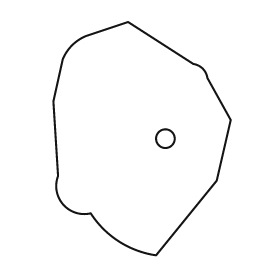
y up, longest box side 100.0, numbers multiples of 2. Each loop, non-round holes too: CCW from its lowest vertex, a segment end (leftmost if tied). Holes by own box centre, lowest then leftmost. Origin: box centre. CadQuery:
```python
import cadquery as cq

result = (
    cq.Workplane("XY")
    .moveTo(6.0, -50.0)
    .lineTo(32.0, -18.0)
    .lineTo(38.0, 8.0)
    .lineTo(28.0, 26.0)
    .threePointArc((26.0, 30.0), (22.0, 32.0))
    .lineTo(-6.0, 50.0)
    .lineTo(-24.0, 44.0)
    .threePointArc((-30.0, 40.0), (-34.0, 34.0))
    .lineTo(-38.0, 16.0)
    .lineTo(-36.0, -16.0)
    .threePointArc((-34.0, -28.0), (-22.0, -32.0))
    .threePointArc((-10.0, -44.0), (6.0, -50.0))
    .close()
    .moveTo(10.0, 0.0)
    .circle(4.0)
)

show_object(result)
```